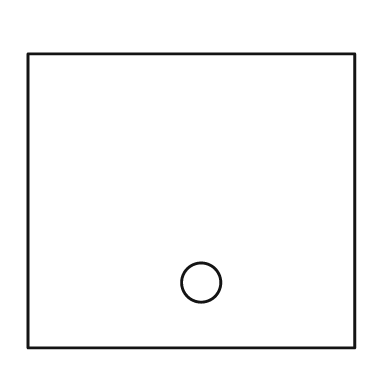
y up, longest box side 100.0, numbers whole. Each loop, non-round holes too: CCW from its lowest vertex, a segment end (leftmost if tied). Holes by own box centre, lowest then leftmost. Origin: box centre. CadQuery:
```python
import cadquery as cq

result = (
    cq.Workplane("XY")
    .moveTo(-50.0, -45.0)
    .lineTo(50.0, -45.0)
    .lineTo(50.0, 45.0)
    .lineTo(-50.0, 45.0)
    .close()
    .moveTo(3.0, -25.0)
    .circle(6.0)
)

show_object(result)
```